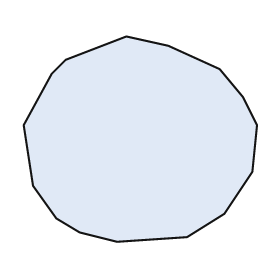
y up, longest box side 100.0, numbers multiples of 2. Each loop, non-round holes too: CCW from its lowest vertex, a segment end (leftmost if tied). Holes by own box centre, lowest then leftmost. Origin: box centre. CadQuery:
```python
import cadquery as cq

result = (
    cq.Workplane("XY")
    .moveTo(-10.0, -44.0)
    .lineTo(20.0, -42.0)
    .lineTo(36.0, -32.0)
    .lineTo(48.0, -14.0)
    .lineTo(50.0, 6.0)
    .lineTo(44.0, 18.0)
    .lineTo(34.0, 30.0)
    .lineTo(12.0, 40.0)
    .lineTo(-6.0, 44.0)
    .lineTo(-32.0, 34.0)
    .lineTo(-38.0, 28.0)
    .lineTo(-50.0, 6.0)
    .lineTo(-46.0, -20.0)
    .lineTo(-36.0, -34.0)
    .lineTo(-26.0, -40.0)
    .close()
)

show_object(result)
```